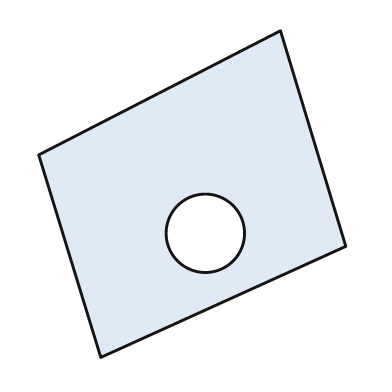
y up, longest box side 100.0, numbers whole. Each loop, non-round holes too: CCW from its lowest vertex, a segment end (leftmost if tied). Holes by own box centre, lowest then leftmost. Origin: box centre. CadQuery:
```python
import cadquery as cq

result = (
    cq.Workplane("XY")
    .moveTo(-28.0, -50.0)
    .lineTo(47.0, -16.0)
    .lineTo(27.0, 50.0)
    .lineTo(-47.0, 12.0)
    .close()
    .moveTo(4.0, -12.0)
    .circle(12.0)
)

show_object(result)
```